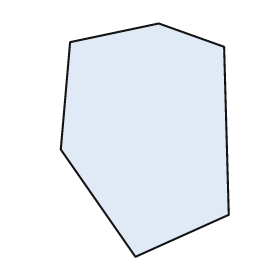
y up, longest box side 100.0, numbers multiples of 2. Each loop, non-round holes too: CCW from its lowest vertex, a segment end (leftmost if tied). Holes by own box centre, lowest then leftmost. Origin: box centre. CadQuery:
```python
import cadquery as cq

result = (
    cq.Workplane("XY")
    .moveTo(-4.0, -50.0)
    .lineTo(36.0, -32.0)
    .lineTo(34.0, 40.0)
    .lineTo(6.0, 50.0)
    .lineTo(-32.0, 42.0)
    .lineTo(-36.0, -4.0)
    .close()
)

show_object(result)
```